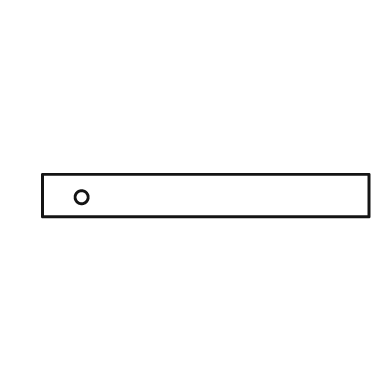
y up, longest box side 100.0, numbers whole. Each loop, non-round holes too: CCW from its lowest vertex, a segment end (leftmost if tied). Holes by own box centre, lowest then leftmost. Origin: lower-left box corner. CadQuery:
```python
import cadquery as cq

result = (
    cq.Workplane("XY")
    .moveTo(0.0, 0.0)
    .lineTo(100.0, 0.0)
    .lineTo(100.0, 13.0)
    .lineTo(0.0, 13.0)
    .close()
    .moveTo(12.0, 6.0)
    .circle(2.0)
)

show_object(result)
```